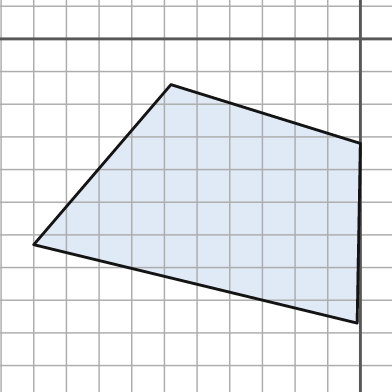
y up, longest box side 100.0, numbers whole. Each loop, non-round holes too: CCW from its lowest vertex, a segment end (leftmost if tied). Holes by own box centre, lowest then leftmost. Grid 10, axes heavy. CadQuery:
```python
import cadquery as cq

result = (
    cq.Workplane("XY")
    .moveTo(-1.0, -87.0)
    .lineTo(0.0, -32.0)
    .lineTo(-58.0, -14.0)
    .lineTo(-100.0, -63.0)
    .close()
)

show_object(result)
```